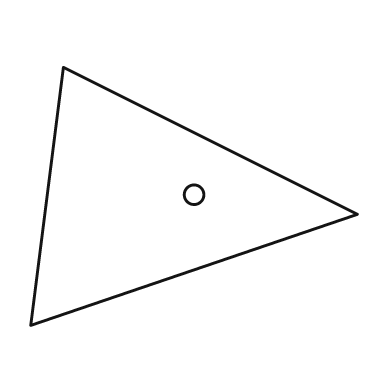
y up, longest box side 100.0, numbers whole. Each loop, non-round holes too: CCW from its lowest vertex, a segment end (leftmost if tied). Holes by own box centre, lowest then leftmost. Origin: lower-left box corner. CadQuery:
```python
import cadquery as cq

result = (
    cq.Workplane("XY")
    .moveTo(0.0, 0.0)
    .lineTo(100.0, 34.0)
    .lineTo(10.0, 79.0)
    .close()
    .moveTo(50.0, 40.0)
    .circle(3.0)
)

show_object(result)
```